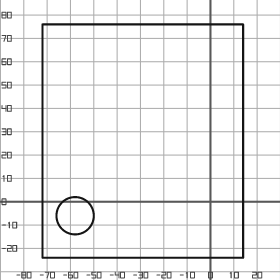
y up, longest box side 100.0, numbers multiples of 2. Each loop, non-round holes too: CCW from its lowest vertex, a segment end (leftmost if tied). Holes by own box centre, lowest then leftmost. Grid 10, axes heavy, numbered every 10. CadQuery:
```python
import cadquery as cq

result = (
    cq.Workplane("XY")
    .moveTo(-72.0, -24.0)
    .lineTo(14.0, -24.0)
    .lineTo(14.0, 76.0)
    .lineTo(-72.0, 76.0)
    .close()
    .moveTo(-58.0, -6.0)
    .circle(8.0)
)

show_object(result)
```